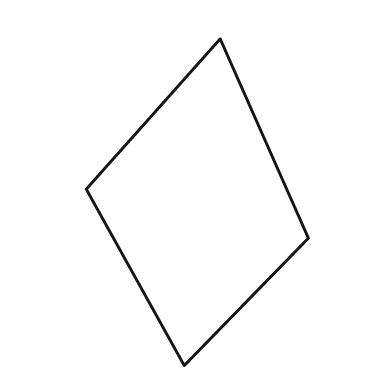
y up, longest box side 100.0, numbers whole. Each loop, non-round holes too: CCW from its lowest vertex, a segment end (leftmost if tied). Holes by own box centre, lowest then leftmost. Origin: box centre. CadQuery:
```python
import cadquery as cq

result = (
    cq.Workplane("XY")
    .moveTo(-4.0, -50.0)
    .lineTo(34.0, -11.0)
    .lineTo(7.0, 50.0)
    .lineTo(-34.0, 4.0)
    .close()
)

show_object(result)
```